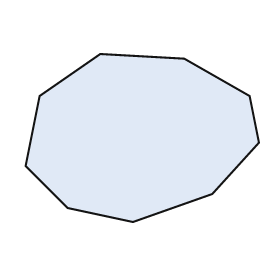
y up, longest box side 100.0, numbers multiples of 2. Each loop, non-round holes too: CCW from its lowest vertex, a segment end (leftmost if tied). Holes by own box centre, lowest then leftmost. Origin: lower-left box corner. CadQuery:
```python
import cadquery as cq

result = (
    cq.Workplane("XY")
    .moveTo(46.0, 0.0)
    .lineTo(80.0, 12.0)
    .lineTo(100.0, 34.0)
    .lineTo(96.0, 54.0)
    .lineTo(68.0, 70.0)
    .lineTo(32.0, 72.0)
    .lineTo(6.0, 54.0)
    .lineTo(0.0, 24.0)
    .lineTo(18.0, 6.0)
    .close()
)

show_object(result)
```